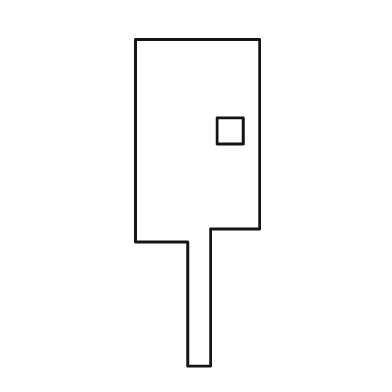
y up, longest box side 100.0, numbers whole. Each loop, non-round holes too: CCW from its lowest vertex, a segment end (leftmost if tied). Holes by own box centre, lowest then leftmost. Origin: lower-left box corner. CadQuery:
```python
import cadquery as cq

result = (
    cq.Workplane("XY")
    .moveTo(16.0, 0.0)
    .lineTo(23.0, 0.0)
    .lineTo(23.0, 42.0)
    .lineTo(38.0, 42.0)
    .lineTo(38.0, 100.0)
    .lineTo(0.0, 100.0)
    .lineTo(0.0, 38.0)
    .lineTo(16.0, 38.0)
    .close()
    .moveTo(25.0, 68.0)
    .lineTo(33.0, 68.0)
    .lineTo(33.0, 76.0)
    .lineTo(25.0, 76.0)
    .close()
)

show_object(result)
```